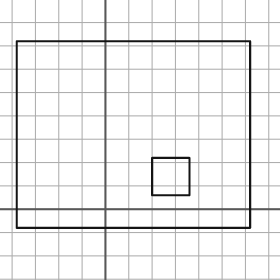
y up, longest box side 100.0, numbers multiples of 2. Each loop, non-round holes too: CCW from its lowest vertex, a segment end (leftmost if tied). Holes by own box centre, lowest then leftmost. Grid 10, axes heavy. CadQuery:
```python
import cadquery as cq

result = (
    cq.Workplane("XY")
    .moveTo(-38.0, -8.0)
    .lineTo(62.0, -8.0)
    .lineTo(62.0, 72.0)
    .lineTo(-38.0, 72.0)
    .close()
    .moveTo(20.0, 6.0)
    .lineTo(36.0, 6.0)
    .lineTo(36.0, 22.0)
    .lineTo(20.0, 22.0)
    .close()
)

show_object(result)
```